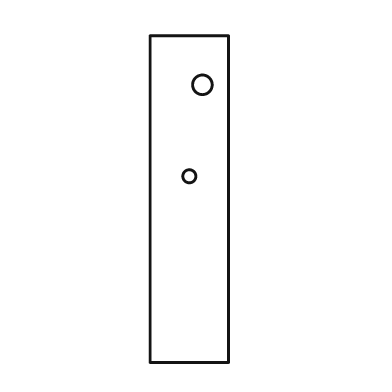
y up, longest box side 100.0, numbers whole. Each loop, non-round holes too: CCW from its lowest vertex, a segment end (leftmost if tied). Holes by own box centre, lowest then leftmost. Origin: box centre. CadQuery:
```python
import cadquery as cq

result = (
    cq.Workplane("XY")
    .moveTo(-12.0, -50.0)
    .lineTo(12.0, -50.0)
    .lineTo(12.0, 50.0)
    .lineTo(-12.0, 50.0)
    .close()
    .moveTo(0.0, 7.0)
    .circle(2.0)
    .moveTo(4.0, 35.0)
    .circle(3.0)
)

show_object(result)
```